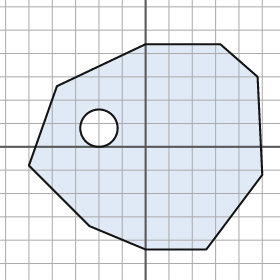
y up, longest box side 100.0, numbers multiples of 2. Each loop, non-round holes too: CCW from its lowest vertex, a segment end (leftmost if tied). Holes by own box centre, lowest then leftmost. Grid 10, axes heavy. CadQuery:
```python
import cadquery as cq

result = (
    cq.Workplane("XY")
    .moveTo(0.0, -44.0)
    .lineTo(26.0, -44.0)
    .lineTo(50.0, -12.0)
    .lineTo(48.0, 30.0)
    .lineTo(32.0, 44.0)
    .lineTo(0.0, 44.0)
    .lineTo(-38.0, 26.0)
    .lineTo(-50.0, -8.0)
    .lineTo(-24.0, -34.0)
    .close()
    .moveTo(-20.0, 8.0)
    .circle(8.0)
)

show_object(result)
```